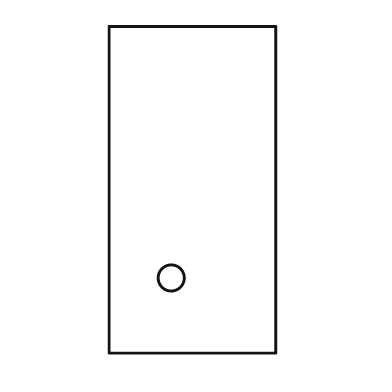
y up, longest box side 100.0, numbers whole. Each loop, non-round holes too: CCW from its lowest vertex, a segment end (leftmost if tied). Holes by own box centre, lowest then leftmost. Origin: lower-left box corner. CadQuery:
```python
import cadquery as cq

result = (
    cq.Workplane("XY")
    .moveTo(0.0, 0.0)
    .lineTo(51.0, 0.0)
    .lineTo(51.0, 100.0)
    .lineTo(0.0, 100.0)
    .close()
    .moveTo(19.0, 23.0)
    .circle(4.0)
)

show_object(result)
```